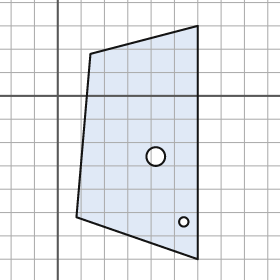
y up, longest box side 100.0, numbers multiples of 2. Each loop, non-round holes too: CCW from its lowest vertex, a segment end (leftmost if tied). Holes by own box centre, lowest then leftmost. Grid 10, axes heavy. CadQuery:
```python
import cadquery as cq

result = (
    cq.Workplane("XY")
    .moveTo(60.0, -70.0)
    .lineTo(60.0, 30.0)
    .lineTo(14.0, 18.0)
    .lineTo(8.0, -52.0)
    .close()
    .moveTo(54.0, -54.0)
    .circle(2.0)
    .moveTo(42.0, -26.0)
    .circle(4.0)
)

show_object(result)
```